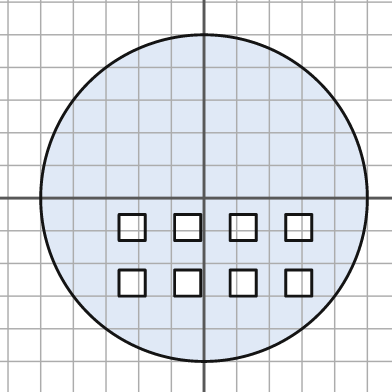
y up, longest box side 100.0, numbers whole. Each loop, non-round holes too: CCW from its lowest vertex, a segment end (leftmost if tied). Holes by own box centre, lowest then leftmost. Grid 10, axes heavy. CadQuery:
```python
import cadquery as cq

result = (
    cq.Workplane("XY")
    .moveTo(0.0, 0.0)
    .circle(50.0)
    .moveTo(-26.0, -30.0)
    .lineTo(-18.0, -30.0)
    .lineTo(-18.0, -22.0)
    .lineTo(-26.0, -22.0)
    .close()
    .moveTo(-9.0, -30.0)
    .lineTo(-1.0, -30.0)
    .lineTo(-1.0, -22.0)
    .lineTo(-9.0, -22.0)
    .close()
    .moveTo(8.0, -30.0)
    .lineTo(16.0, -30.0)
    .lineTo(16.0, -22.0)
    .lineTo(8.0, -22.0)
    .close()
    .moveTo(25.0, -30.0)
    .lineTo(33.0, -30.0)
    .lineTo(33.0, -22.0)
    .lineTo(25.0, -22.0)
    .close()
    .moveTo(-26.0, -13.0)
    .lineTo(-18.0, -13.0)
    .lineTo(-18.0, -5.0)
    .lineTo(-26.0, -5.0)
    .close()
    .moveTo(-9.0, -13.0)
    .lineTo(-1.0, -13.0)
    .lineTo(-1.0, -5.0)
    .lineTo(-9.0, -5.0)
    .close()
    .moveTo(8.0, -13.0)
    .lineTo(16.0, -13.0)
    .lineTo(16.0, -5.0)
    .lineTo(8.0, -5.0)
    .close()
    .moveTo(25.0, -13.0)
    .lineTo(33.0, -13.0)
    .lineTo(33.0, -5.0)
    .lineTo(25.0, -5.0)
    .close()
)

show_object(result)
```